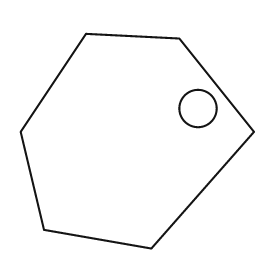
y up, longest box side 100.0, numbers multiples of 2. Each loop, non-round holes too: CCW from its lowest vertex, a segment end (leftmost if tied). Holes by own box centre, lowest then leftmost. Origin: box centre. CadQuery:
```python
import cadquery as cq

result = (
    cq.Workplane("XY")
    .moveTo(6.0, -46.0)
    .lineTo(50.0, 4.0)
    .lineTo(18.0, 44.0)
    .lineTo(-22.0, 46.0)
    .lineTo(-50.0, 4.0)
    .lineTo(-40.0, -38.0)
    .close()
    .moveTo(26.0, 14.0)
    .circle(8.0)
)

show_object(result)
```